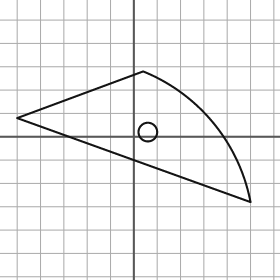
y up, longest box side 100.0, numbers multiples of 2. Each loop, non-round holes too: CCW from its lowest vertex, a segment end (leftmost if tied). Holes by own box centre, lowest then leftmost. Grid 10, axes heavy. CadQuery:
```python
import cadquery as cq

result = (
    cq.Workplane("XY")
    .moveTo(50.0, -28.0)
    .threePointArc((34.0, 6.0), (4.0, 28.0))
    .lineTo(-50.0, 8.0)
    .close()
    .moveTo(6.0, 2.0)
    .circle(4.0)
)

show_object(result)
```